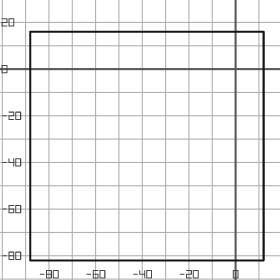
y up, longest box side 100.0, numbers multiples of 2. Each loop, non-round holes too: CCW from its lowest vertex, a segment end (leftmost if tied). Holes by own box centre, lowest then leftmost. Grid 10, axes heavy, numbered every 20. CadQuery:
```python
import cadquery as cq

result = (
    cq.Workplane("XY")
    .moveTo(-88.0, -82.0)
    .lineTo(12.0, -82.0)
    .lineTo(12.0, 16.0)
    .lineTo(-88.0, 16.0)
    .close()
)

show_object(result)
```